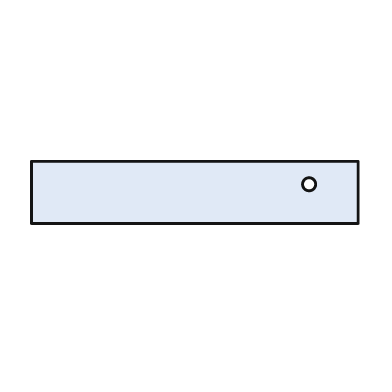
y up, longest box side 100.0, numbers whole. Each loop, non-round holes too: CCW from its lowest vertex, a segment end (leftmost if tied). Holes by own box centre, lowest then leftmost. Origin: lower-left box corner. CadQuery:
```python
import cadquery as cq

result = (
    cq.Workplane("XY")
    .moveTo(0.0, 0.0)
    .lineTo(100.0, 0.0)
    .lineTo(100.0, 19.0)
    .lineTo(0.0, 19.0)
    .close()
    .moveTo(85.0, 12.0)
    .circle(2.0)
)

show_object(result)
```